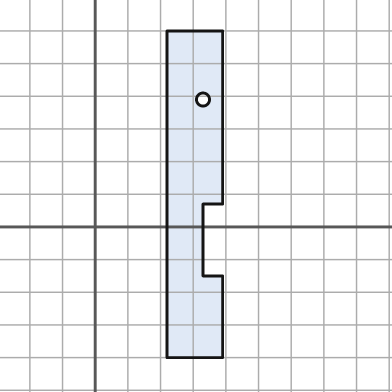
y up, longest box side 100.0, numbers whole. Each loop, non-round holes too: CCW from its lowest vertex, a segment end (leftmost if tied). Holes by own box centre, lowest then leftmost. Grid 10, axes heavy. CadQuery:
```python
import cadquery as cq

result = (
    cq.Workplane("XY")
    .moveTo(22.0, -40.0)
    .lineTo(39.0, -40.0)
    .lineTo(39.0, -15.0)
    .lineTo(33.0, -15.0)
    .lineTo(33.0, 7.0)
    .lineTo(39.0, 7.0)
    .lineTo(39.0, 60.0)
    .lineTo(22.0, 60.0)
    .close()
    .moveTo(33.0, 39.0)
    .circle(2.0)
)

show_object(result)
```